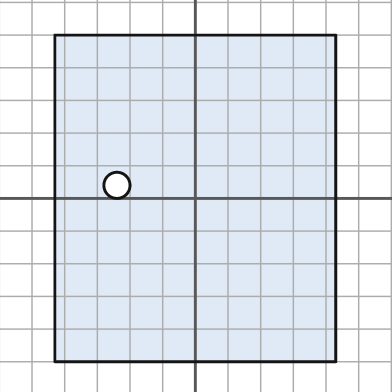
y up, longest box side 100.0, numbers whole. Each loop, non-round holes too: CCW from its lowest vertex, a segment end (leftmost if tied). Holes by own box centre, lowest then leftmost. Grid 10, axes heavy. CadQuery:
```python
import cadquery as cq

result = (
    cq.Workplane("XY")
    .moveTo(-43.0, -50.0)
    .lineTo(43.0, -50.0)
    .lineTo(43.0, 50.0)
    .lineTo(-43.0, 50.0)
    .close()
    .moveTo(-24.0, 4.0)
    .circle(4.0)
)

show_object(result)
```